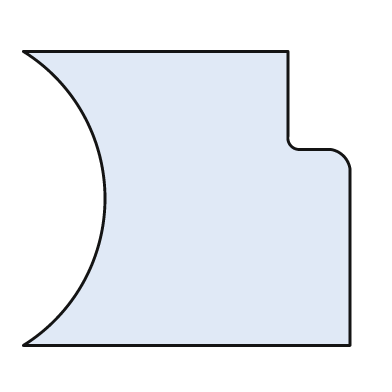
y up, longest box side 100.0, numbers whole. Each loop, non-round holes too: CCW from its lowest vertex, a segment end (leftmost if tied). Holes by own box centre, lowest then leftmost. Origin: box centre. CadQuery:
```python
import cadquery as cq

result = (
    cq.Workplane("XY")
    .moveTo(-50.0, -45.0)
    .lineTo(50.0, -45.0)
    .lineTo(50.0, 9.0)
    .threePointArc((48.0, 13.0), (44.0, 15.0))
    .lineTo(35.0, 15.0)
    .threePointArc((32.0, 16.0), (31.0, 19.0))
    .lineTo(31.0, 45.0)
    .lineTo(-50.0, 45.0)
    .threePointArc((-25.0, 0.0), (-50.0, -45.0))
    .close()
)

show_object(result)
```